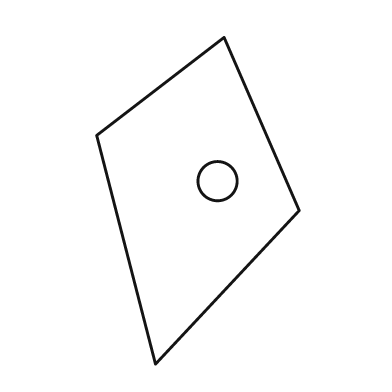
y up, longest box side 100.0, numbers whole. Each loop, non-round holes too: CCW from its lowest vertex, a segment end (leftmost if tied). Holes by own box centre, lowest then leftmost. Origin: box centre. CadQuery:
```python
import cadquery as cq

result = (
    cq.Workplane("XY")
    .moveTo(-13.0, -50.0)
    .lineTo(31.0, -3.0)
    .lineTo(8.0, 50.0)
    .lineTo(-31.0, 20.0)
    .close()
    .moveTo(6.0, 6.0)
    .circle(6.0)
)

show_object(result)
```